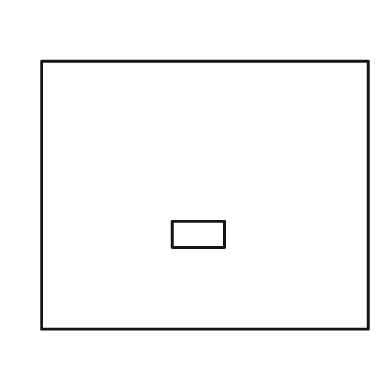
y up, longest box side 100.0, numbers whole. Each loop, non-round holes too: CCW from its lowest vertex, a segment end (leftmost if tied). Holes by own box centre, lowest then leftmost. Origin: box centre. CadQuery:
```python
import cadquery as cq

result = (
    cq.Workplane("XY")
    .moveTo(-50.0, -41.0)
    .lineTo(50.0, -41.0)
    .lineTo(50.0, 41.0)
    .lineTo(-50.0, 41.0)
    .close()
    .moveTo(-10.0, -16.0)
    .lineTo(6.0, -16.0)
    .lineTo(6.0, -8.0)
    .lineTo(-10.0, -8.0)
    .close()
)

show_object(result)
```